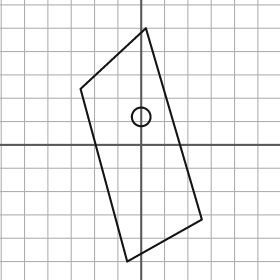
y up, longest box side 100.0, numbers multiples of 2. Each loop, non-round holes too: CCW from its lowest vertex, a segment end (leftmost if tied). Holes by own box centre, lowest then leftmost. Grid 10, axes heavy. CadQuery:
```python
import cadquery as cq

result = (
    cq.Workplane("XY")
    .moveTo(-6.0, -50.0)
    .lineTo(26.0, -32.0)
    .lineTo(2.0, 50.0)
    .lineTo(-26.0, 24.0)
    .close()
    .moveTo(0.0, 12.0)
    .circle(4.0)
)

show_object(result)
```